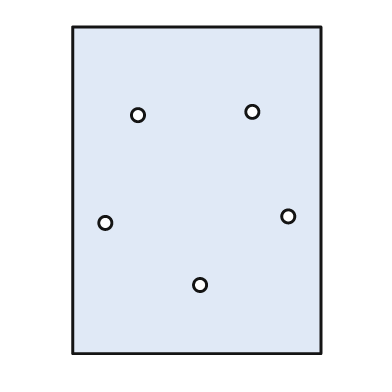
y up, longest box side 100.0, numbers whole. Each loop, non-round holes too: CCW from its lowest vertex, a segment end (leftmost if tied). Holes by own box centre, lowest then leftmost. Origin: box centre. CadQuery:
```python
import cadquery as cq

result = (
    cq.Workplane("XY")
    .moveTo(-38.0, -50.0)
    .lineTo(38.0, -50.0)
    .lineTo(38.0, 50.0)
    .lineTo(-38.0, 50.0)
    .close()
    .moveTo(1.0, -29.0)
    .circle(2.0)
    .moveTo(-28.0, -10.0)
    .circle(2.0)
    .moveTo(28.0, -8.0)
    .circle(2.0)
    .moveTo(-18.0, 23.0)
    .circle(2.0)
    .moveTo(17.0, 24.0)
    .circle(2.0)
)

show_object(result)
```